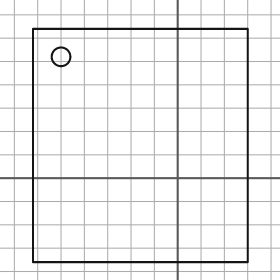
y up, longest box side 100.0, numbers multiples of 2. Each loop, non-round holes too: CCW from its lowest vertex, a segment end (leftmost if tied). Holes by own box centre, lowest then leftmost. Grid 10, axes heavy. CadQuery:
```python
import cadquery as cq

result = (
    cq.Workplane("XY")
    .moveTo(-62.0, -36.0)
    .lineTo(30.0, -36.0)
    .lineTo(30.0, 64.0)
    .lineTo(-62.0, 64.0)
    .close()
    .moveTo(-50.0, 52.0)
    .circle(4.0)
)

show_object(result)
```